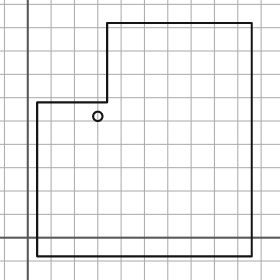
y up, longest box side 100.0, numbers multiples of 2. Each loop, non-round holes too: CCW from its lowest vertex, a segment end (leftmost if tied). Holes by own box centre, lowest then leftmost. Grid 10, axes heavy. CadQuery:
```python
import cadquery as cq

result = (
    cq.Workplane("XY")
    .moveTo(4.0, -8.0)
    .lineTo(96.0, -8.0)
    .lineTo(96.0, 92.0)
    .lineTo(34.0, 92.0)
    .lineTo(34.0, 58.0)
    .lineTo(4.0, 58.0)
    .close()
    .moveTo(30.0, 52.0)
    .circle(2.0)
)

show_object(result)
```